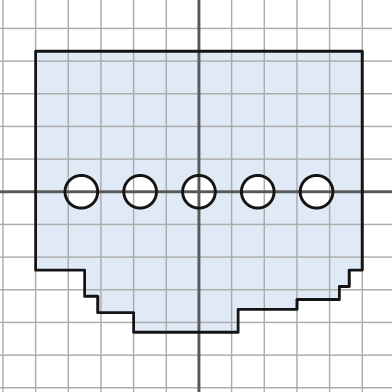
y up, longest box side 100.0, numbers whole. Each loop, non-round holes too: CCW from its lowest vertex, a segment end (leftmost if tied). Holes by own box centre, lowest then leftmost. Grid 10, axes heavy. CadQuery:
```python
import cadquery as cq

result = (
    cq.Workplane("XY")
    .moveTo(-20.0, -43.0)
    .lineTo(12.0, -43.0)
    .lineTo(12.0, -36.0)
    .lineTo(30.0, -36.0)
    .lineTo(30.0, -33.0)
    .lineTo(43.0, -33.0)
    .lineTo(43.0, -29.0)
    .lineTo(46.0, -29.0)
    .lineTo(46.0, -24.0)
    .lineTo(50.0, -24.0)
    .lineTo(50.0, 43.0)
    .lineTo(-50.0, 43.0)
    .lineTo(-50.0, -24.0)
    .lineTo(-35.0, -24.0)
    .lineTo(-35.0, -32.0)
    .lineTo(-31.0, -32.0)
    .lineTo(-31.0, -37.0)
    .lineTo(-20.0, -37.0)
    .close()
    .moveTo(-36.0, 0.0)
    .circle(5.0)
    .moveTo(-18.0, 0.0)
    .circle(5.0)
    .moveTo(0.0, 0.0)
    .circle(5.0)
    .moveTo(18.0, 0.0)
    .circle(5.0)
    .moveTo(36.0, 0.0)
    .circle(5.0)
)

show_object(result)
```